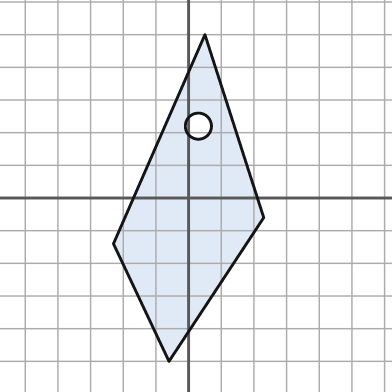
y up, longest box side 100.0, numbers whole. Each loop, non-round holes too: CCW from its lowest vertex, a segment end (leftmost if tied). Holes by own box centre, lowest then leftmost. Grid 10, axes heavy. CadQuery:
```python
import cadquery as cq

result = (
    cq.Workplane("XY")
    .moveTo(-6.0, -50.0)
    .lineTo(23.0, -6.0)
    .lineTo(5.0, 50.0)
    .lineTo(-23.0, -14.0)
    .close()
    .moveTo(3.0, 22.0)
    .circle(4.0)
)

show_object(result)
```